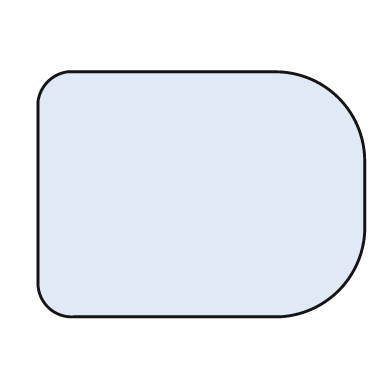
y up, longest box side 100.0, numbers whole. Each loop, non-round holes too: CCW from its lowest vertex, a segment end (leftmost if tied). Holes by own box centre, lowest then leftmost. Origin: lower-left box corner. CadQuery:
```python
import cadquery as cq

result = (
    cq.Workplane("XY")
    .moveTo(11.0, 0.0)
    .lineTo(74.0, 0.0)
    .threePointArc((92.0, 8.0), (100.0, 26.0))
    .lineTo(100.0, 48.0)
    .threePointArc((92.0, 67.0), (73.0, 75.0))
    .lineTo(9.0, 75.0)
    .threePointArc((3.0, 72.0), (0.0, 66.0))
    .lineTo(0.0, 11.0)
    .threePointArc((3.0, 3.0), (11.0, 0.0))
    .close()
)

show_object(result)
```